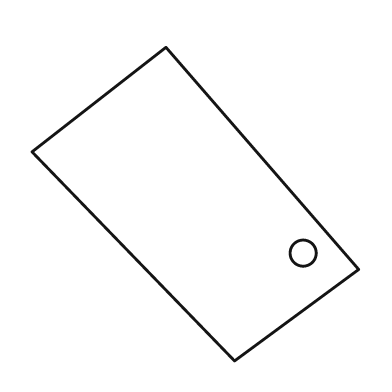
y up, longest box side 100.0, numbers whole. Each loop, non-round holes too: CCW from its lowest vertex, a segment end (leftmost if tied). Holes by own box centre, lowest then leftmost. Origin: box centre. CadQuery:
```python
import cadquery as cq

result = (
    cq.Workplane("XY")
    .moveTo(12.0, -48.0)
    .lineTo(50.0, -20.0)
    .lineTo(-9.0, 48.0)
    .lineTo(-50.0, 16.0)
    .close()
    .moveTo(33.0, -15.0)
    .circle(4.0)
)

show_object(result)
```